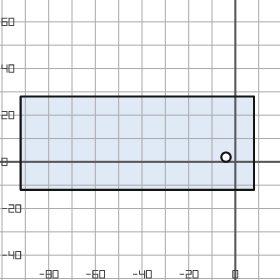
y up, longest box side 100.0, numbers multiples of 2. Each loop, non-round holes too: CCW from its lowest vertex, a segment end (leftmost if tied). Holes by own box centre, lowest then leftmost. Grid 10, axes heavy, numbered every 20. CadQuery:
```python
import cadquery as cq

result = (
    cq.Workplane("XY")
    .moveTo(-92.0, -12.0)
    .lineTo(8.0, -12.0)
    .lineTo(8.0, 28.0)
    .lineTo(-92.0, 28.0)
    .close()
    .moveTo(-4.0, 2.0)
    .circle(2.0)
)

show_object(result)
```